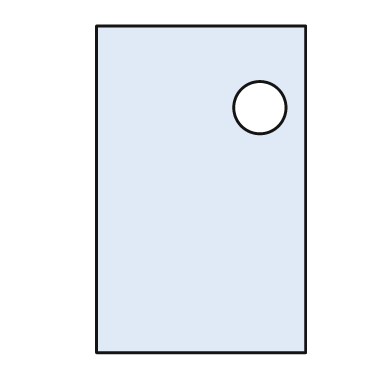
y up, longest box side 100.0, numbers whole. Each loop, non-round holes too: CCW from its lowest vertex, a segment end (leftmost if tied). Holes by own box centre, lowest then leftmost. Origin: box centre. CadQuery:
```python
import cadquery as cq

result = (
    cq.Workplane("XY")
    .moveTo(-32.0, -50.0)
    .lineTo(32.0, -50.0)
    .lineTo(32.0, 50.0)
    .lineTo(-32.0, 50.0)
    .close()
    .moveTo(18.0, 25.0)
    .circle(8.0)
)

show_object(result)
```